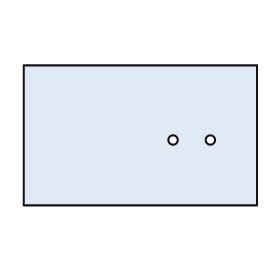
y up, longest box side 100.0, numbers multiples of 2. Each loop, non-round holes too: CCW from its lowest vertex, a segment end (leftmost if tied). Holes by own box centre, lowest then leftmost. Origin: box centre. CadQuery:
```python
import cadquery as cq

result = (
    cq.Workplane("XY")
    .moveTo(-50.0, -30.0)
    .lineTo(50.0, -30.0)
    .lineTo(50.0, 30.0)
    .lineTo(-50.0, 30.0)
    .close()
    .moveTo(14.0, -2.0)
    .circle(2.0)
    .moveTo(30.0, -2.0)
    .circle(2.0)
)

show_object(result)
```